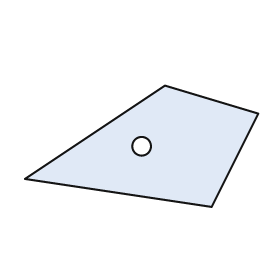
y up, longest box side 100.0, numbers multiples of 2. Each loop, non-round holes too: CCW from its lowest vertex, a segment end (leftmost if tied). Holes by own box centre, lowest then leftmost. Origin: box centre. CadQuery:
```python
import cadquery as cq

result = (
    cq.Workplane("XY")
    .moveTo(30.0, -26.0)
    .lineTo(50.0, 14.0)
    .lineTo(10.0, 26.0)
    .lineTo(-50.0, -14.0)
    .close()
    .moveTo(0.0, 0.0)
    .circle(4.0)
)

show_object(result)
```